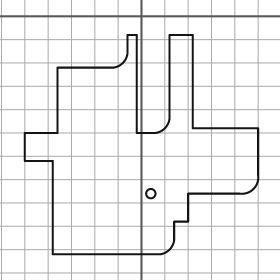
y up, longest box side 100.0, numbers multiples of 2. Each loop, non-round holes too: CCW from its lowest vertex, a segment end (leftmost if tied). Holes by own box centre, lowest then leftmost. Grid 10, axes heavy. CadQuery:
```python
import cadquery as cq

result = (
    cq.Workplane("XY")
    .moveTo(-38.0, -102.0)
    .lineTo(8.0, -102.0)
    .threePointArc((12.0, -100.0), (14.0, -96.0))
    .lineTo(14.0, -88.0)
    .lineTo(20.0, -88.0)
    .lineTo(20.0, -76.0)
    .lineTo(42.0, -76.0)
    .threePointArc((48.0, -74.0), (50.0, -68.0))
    .lineTo(50.0, -48.0)
    .lineTo(22.0, -48.0)
    .lineTo(22.0, -8.0)
    .lineTo(12.0, -8.0)
    .lineTo(12.0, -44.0)
    .threePointArc((10.0, -48.0), (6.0, -50.0))
    .lineTo(-2.0, -50.0)
    .lineTo(-2.0, -8.0)
    .lineTo(-6.0, -8.0)
    .lineTo(-6.0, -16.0)
    .threePointArc((-8.0, -20.0), (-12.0, -22.0))
    .lineTo(-36.0, -22.0)
    .lineTo(-36.0, -50.0)
    .lineTo(-50.0, -50.0)
    .lineTo(-50.0, -62.0)
    .lineTo(-38.0, -62.0)
    .close()
    .moveTo(4.0, -76.0)
    .circle(2.0)
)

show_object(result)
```